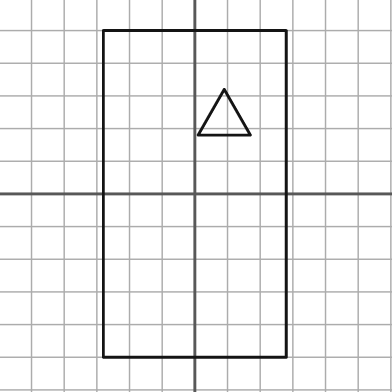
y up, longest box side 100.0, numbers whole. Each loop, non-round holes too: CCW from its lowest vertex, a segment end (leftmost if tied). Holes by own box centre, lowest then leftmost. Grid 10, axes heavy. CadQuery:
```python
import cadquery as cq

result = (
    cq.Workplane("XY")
    .moveTo(-28.0, -50.0)
    .lineTo(28.0, -50.0)
    .lineTo(28.0, 50.0)
    .lineTo(-28.0, 50.0)
    .close()
    .moveTo(1.0, 18.0)
    .lineTo(17.0, 18.0)
    .lineTo(9.0, 32.0)
    .close()
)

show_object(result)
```